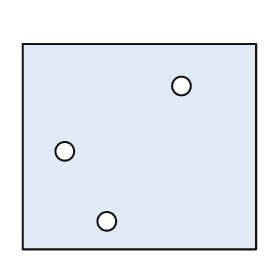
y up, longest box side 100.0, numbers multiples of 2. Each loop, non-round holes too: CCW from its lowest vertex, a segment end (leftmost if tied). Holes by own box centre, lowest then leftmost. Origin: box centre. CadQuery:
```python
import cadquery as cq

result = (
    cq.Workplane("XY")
    .moveTo(-50.0, -44.0)
    .lineTo(50.0, -44.0)
    .lineTo(50.0, 44.0)
    .lineTo(-50.0, 44.0)
    .close()
    .moveTo(-14.0, -32.0)
    .circle(4.0)
    .moveTo(-32.0, -2.0)
    .circle(4.0)
    .moveTo(18.0, 26.0)
    .circle(4.0)
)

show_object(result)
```